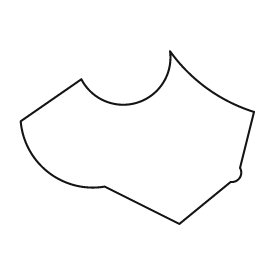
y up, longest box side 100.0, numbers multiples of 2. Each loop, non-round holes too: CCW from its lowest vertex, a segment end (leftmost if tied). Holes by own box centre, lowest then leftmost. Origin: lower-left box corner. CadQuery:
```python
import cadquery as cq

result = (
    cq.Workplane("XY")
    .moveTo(68.0, 0.0)
    .lineTo(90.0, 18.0)
    .threePointArc((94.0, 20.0), (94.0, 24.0))
    .lineTo(100.0, 48.0)
    .threePointArc((80.0, 58.0), (64.0, 74.0))
    .threePointArc((50.0, 52.0), (26.0, 62.0))
    .lineTo(0.0, 44.0)
    .threePointArc((12.0, 22.0), (36.0, 16.0))
    .close()
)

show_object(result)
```